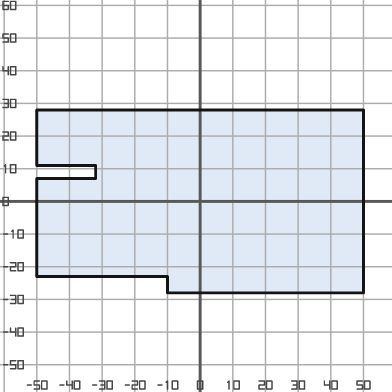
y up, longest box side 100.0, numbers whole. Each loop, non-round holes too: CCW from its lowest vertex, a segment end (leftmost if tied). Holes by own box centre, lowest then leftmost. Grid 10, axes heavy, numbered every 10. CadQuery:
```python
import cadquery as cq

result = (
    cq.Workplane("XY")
    .moveTo(-10.0, -28.0)
    .lineTo(50.0, -28.0)
    .lineTo(50.0, 28.0)
    .lineTo(-50.0, 28.0)
    .lineTo(-50.0, 11.0)
    .lineTo(-32.0, 11.0)
    .lineTo(-32.0, 7.0)
    .lineTo(-50.0, 7.0)
    .lineTo(-50.0, -23.0)
    .lineTo(-10.0, -23.0)
    .close()
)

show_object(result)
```